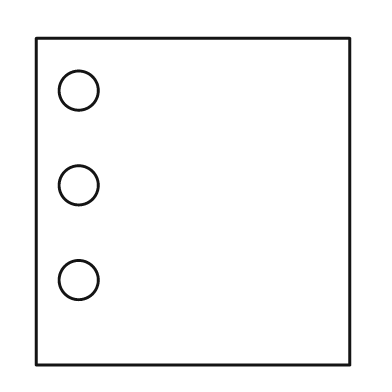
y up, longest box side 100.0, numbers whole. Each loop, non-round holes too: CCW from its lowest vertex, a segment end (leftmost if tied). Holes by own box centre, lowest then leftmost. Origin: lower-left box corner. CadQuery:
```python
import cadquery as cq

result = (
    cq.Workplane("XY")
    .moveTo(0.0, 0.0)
    .lineTo(96.0, 0.0)
    .lineTo(96.0, 100.0)
    .lineTo(0.0, 100.0)
    .close()
    .moveTo(13.0, 26.0)
    .circle(6.0)
    .moveTo(13.0, 55.0)
    .circle(6.0)
    .moveTo(13.0, 84.0)
    .circle(6.0)
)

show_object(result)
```